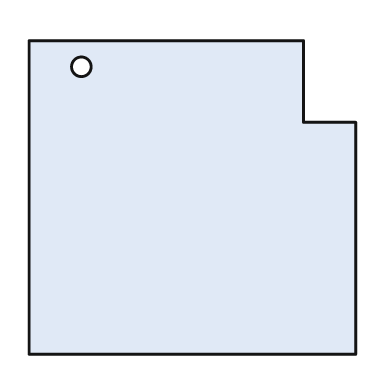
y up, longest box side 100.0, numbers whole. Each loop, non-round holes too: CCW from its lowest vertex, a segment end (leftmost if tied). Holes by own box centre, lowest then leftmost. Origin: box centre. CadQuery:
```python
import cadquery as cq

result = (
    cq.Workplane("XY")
    .moveTo(-50.0, -48.0)
    .lineTo(50.0, -48.0)
    .lineTo(50.0, 23.0)
    .lineTo(34.0, 23.0)
    .lineTo(34.0, 48.0)
    .lineTo(-50.0, 48.0)
    .close()
    .moveTo(-34.0, 40.0)
    .circle(3.0)
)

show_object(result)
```